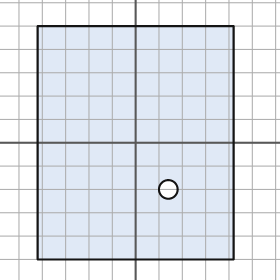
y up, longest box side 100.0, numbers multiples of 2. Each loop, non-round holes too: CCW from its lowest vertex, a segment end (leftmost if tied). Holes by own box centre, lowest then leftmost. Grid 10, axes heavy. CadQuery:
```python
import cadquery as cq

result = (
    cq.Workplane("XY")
    .moveTo(-42.0, -50.0)
    .lineTo(42.0, -50.0)
    .lineTo(42.0, 50.0)
    .lineTo(-42.0, 50.0)
    .close()
    .moveTo(14.0, -20.0)
    .circle(4.0)
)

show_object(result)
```